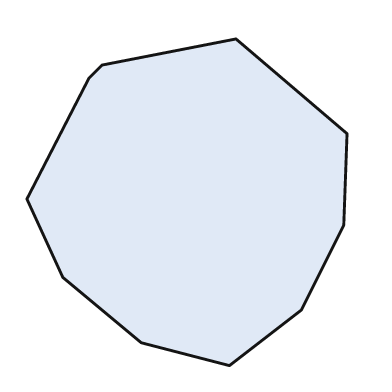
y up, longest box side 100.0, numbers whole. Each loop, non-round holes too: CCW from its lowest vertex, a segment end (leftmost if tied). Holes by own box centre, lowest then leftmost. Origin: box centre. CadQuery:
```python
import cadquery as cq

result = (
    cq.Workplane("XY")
    .moveTo(13.0, -50.0)
    .lineTo(35.0, -33.0)
    .lineTo(48.0, -7.0)
    .lineTo(49.0, 21.0)
    .lineTo(15.0, 50.0)
    .lineTo(-26.0, 42.0)
    .lineTo(-30.0, 38.0)
    .lineTo(-49.0, 1.0)
    .lineTo(-38.0, -23.0)
    .lineTo(-14.0, -43.0)
    .close()
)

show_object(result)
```